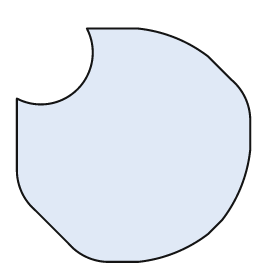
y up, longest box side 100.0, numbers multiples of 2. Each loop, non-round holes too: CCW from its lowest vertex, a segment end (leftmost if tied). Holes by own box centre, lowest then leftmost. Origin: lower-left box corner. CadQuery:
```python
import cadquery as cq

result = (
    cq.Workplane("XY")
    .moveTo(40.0, 0.0)
    .lineTo(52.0, 0.0)
    .threePointArc((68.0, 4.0), (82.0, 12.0))
    .lineTo(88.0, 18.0)
    .threePointArc((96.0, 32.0), (100.0, 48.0))
    .lineTo(100.0, 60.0)
    .threePointArc((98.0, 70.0), (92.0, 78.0))
    .lineTo(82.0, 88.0)
    .threePointArc((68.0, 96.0), (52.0, 100.0))
    .lineTo(30.0, 100.0)
    .threePointArc((26.0, 74.0), (0.0, 70.0))
    .lineTo(0.0, 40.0)
    .threePointArc((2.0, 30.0), (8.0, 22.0))
    .lineTo(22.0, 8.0)
    .threePointArc((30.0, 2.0), (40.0, 0.0))
    .close()
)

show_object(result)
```